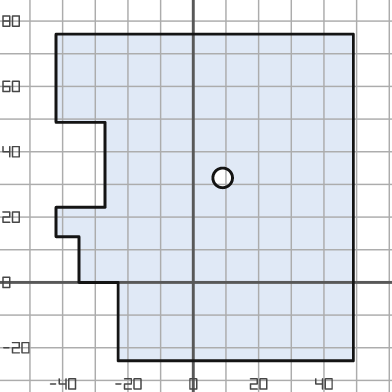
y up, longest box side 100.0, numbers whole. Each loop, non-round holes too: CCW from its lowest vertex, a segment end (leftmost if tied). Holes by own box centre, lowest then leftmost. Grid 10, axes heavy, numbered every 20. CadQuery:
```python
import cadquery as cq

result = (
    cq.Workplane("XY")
    .moveTo(-23.0, -24.0)
    .lineTo(49.0, -24.0)
    .lineTo(49.0, 76.0)
    .lineTo(-42.0, 76.0)
    .lineTo(-42.0, 49.0)
    .lineTo(-27.0, 49.0)
    .lineTo(-27.0, 23.0)
    .lineTo(-42.0, 23.0)
    .lineTo(-42.0, 14.0)
    .lineTo(-35.0, 14.0)
    .lineTo(-35.0, 0.0)
    .lineTo(-23.0, 0.0)
    .close()
    .moveTo(9.0, 32.0)
    .circle(3.0)
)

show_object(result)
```